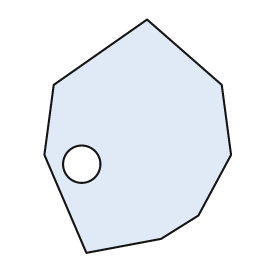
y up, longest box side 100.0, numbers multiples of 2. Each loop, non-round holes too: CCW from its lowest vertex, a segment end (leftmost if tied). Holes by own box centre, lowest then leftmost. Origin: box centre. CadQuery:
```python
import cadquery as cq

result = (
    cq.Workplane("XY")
    .moveTo(-22.0, -50.0)
    .lineTo(10.0, -44.0)
    .lineTo(26.0, -34.0)
    .lineTo(40.0, -8.0)
    .lineTo(36.0, 22.0)
    .lineTo(4.0, 50.0)
    .lineTo(-36.0, 22.0)
    .lineTo(-40.0, -8.0)
    .close()
    .moveTo(-24.0, -12.0)
    .circle(8.0)
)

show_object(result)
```